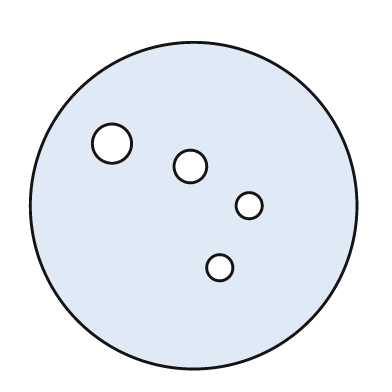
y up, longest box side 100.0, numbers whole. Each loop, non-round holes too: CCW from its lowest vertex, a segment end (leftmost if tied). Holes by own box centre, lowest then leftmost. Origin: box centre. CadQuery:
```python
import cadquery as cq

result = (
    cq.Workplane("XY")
    .moveTo(0.0, 0.0)
    .circle(50.0)
    .moveTo(8.0, -19.0)
    .circle(4.0)
    .moveTo(17.0, 0.0)
    .circle(4.0)
    .moveTo(-1.0, 12.0)
    .circle(5.0)
    .moveTo(-25.0, 19.0)
    .circle(6.0)
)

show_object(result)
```